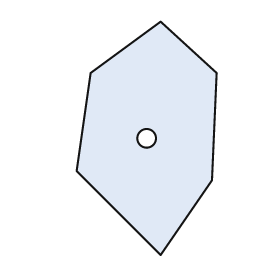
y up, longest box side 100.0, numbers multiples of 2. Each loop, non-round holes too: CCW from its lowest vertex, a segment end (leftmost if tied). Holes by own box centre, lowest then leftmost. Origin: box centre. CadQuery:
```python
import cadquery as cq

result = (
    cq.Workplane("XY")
    .moveTo(6.0, -50.0)
    .lineTo(28.0, -18.0)
    .lineTo(30.0, 28.0)
    .lineTo(6.0, 50.0)
    .lineTo(-24.0, 28.0)
    .lineTo(-30.0, -14.0)
    .close()
    .moveTo(0.0, 0.0)
    .circle(4.0)
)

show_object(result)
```